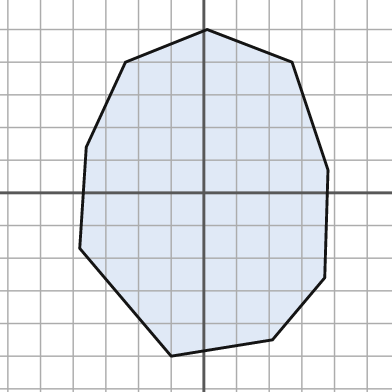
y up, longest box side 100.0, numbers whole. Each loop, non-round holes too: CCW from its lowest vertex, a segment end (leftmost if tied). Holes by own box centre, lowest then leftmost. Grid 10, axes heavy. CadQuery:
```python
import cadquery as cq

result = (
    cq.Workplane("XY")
    .moveTo(-10.0, -50.0)
    .lineTo(21.0, -45.0)
    .lineTo(37.0, -26.0)
    .lineTo(38.0, 7.0)
    .lineTo(27.0, 40.0)
    .lineTo(1.0, 50.0)
    .lineTo(-24.0, 40.0)
    .lineTo(-36.0, 14.0)
    .lineTo(-38.0, -17.0)
    .close()
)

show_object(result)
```